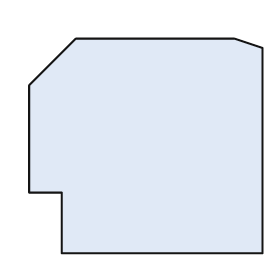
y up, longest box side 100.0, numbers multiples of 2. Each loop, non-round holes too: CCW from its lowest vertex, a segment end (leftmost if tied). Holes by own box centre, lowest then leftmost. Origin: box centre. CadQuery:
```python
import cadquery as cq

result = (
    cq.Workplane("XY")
    .moveTo(-36.0, -46.0)
    .lineTo(50.0, -46.0)
    .lineTo(50.0, 42.0)
    .lineTo(38.0, 46.0)
    .lineTo(-30.0, 46.0)
    .lineTo(-50.0, 26.0)
    .lineTo(-50.0, -20.0)
    .lineTo(-36.0, -20.0)
    .close()
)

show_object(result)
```